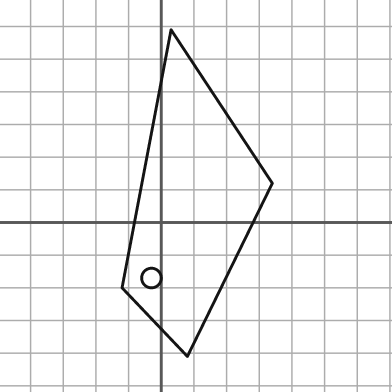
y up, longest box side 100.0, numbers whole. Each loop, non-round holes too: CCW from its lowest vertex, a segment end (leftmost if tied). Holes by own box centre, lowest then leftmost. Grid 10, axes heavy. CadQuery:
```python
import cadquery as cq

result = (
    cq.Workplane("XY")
    .moveTo(8.0, -41.0)
    .lineTo(34.0, 12.0)
    .lineTo(3.0, 59.0)
    .lineTo(-12.0, -20.0)
    .close()
    .moveTo(-3.0, -17.0)
    .circle(3.0)
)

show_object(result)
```